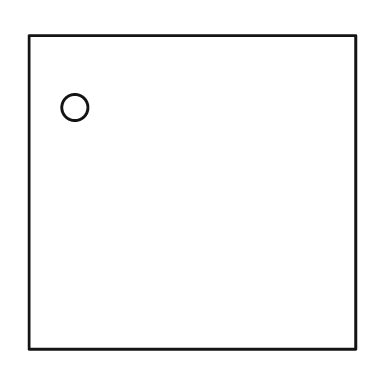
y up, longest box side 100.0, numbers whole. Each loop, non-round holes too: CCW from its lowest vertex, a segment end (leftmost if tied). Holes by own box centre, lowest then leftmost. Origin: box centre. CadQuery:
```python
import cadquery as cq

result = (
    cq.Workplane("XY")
    .moveTo(-50.0, -48.0)
    .lineTo(50.0, -48.0)
    .lineTo(50.0, 48.0)
    .lineTo(-50.0, 48.0)
    .close()
    .moveTo(-36.0, 26.0)
    .circle(4.0)
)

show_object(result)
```